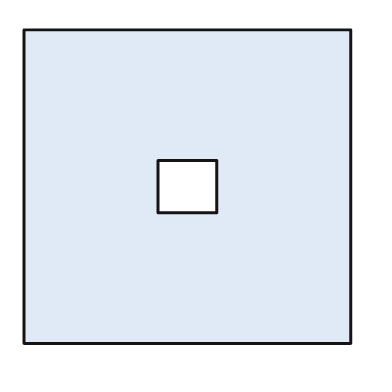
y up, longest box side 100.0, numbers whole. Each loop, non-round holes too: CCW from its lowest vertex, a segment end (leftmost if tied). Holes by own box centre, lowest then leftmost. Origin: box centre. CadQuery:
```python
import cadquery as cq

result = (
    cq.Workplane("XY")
    .moveTo(-50.0, -48.0)
    .lineTo(50.0, -48.0)
    .lineTo(50.0, 48.0)
    .lineTo(-50.0, 48.0)
    .close()
    .moveTo(-9.0, -8.0)
    .lineTo(9.0, -8.0)
    .lineTo(9.0, 8.0)
    .lineTo(-9.0, 8.0)
    .close()
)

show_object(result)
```